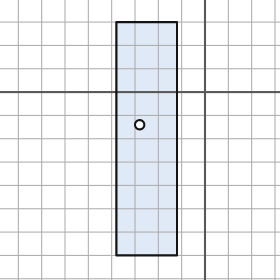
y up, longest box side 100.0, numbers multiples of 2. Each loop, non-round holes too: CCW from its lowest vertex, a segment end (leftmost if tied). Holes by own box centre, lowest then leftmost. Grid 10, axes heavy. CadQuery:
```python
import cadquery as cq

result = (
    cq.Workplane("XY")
    .moveTo(-38.0, -70.0)
    .lineTo(-12.0, -70.0)
    .lineTo(-12.0, 30.0)
    .lineTo(-38.0, 30.0)
    .close()
    .moveTo(-28.0, -14.0)
    .circle(2.0)
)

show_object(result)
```